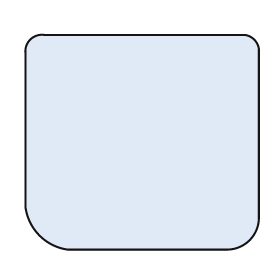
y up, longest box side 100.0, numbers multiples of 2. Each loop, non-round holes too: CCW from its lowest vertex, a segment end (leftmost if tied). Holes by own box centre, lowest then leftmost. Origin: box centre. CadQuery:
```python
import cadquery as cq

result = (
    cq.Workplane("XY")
    .moveTo(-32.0, -46.0)
    .lineTo(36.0, -46.0)
    .threePointArc((46.0, -42.0), (50.0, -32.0))
    .lineTo(50.0, 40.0)
    .threePointArc((48.0, 44.0), (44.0, 46.0))
    .lineTo(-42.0, 46.0)
    .threePointArc((-48.0, 44.0), (-50.0, 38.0))
    .lineTo(-50.0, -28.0)
    .threePointArc((-44.0, -40.0), (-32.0, -46.0))
    .close()
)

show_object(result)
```